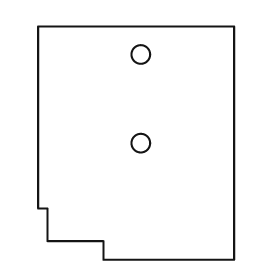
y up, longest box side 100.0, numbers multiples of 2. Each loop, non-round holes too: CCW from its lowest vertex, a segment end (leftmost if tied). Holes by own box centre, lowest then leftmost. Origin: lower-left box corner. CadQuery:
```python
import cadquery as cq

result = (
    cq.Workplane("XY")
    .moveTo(28.0, 0.0)
    .lineTo(84.0, 0.0)
    .lineTo(84.0, 100.0)
    .lineTo(0.0, 100.0)
    .lineTo(0.0, 22.0)
    .lineTo(4.0, 22.0)
    .lineTo(4.0, 8.0)
    .lineTo(28.0, 8.0)
    .close()
    .moveTo(44.0, 50.0)
    .circle(4.0)
    .moveTo(44.0, 88.0)
    .circle(4.0)
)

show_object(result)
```